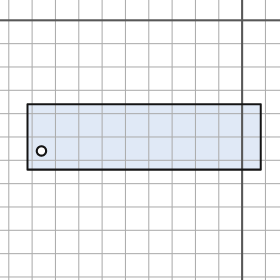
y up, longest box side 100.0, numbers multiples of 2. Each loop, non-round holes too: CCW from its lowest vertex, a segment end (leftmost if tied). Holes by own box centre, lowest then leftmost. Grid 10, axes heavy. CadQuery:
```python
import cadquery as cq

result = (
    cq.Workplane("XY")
    .moveTo(-92.0, -64.0)
    .lineTo(8.0, -64.0)
    .lineTo(8.0, -36.0)
    .lineTo(-92.0, -36.0)
    .close()
    .moveTo(-86.0, -56.0)
    .circle(2.0)
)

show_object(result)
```